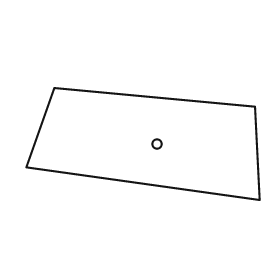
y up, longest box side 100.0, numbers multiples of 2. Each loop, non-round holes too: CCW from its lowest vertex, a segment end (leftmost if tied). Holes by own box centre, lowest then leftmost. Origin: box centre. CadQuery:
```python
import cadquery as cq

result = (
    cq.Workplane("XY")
    .moveTo(50.0, -24.0)
    .lineTo(48.0, 16.0)
    .lineTo(-38.0, 24.0)
    .lineTo(-50.0, -10.0)
    .close()
    .moveTo(6.0, 0.0)
    .circle(2.0)
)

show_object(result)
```